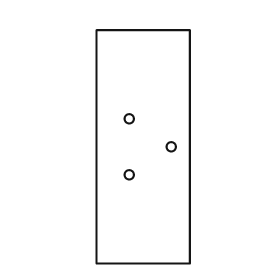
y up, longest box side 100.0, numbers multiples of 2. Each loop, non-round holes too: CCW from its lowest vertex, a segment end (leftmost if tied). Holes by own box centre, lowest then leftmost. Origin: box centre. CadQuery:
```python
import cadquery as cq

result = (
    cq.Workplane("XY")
    .moveTo(-20.0, -50.0)
    .lineTo(20.0, -50.0)
    .lineTo(20.0, 50.0)
    .lineTo(-20.0, 50.0)
    .close()
    .moveTo(-6.0, -12.0)
    .circle(2.0)
    .moveTo(12.0, 0.0)
    .circle(2.0)
    .moveTo(-6.0, 12.0)
    .circle(2.0)
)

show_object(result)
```